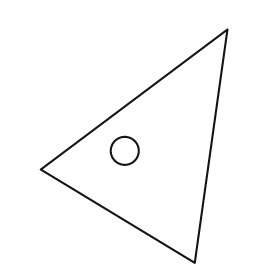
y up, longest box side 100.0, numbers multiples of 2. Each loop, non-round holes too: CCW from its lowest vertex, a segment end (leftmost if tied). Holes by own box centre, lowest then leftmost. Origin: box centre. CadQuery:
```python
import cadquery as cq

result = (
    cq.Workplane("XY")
    .moveTo(26.0, -50.0)
    .lineTo(40.0, 50.0)
    .lineTo(-40.0, -10.0)
    .close()
    .moveTo(-4.0, -2.0)
    .circle(6.0)
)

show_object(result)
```